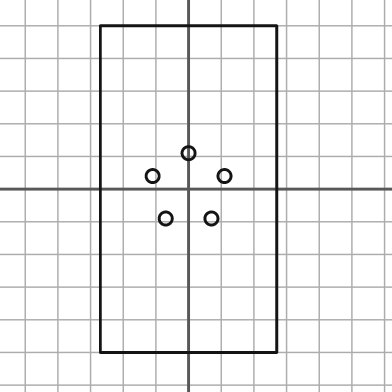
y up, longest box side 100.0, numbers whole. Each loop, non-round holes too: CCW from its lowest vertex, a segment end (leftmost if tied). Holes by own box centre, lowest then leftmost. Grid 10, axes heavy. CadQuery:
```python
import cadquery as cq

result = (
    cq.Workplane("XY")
    .moveTo(-27.0, -50.0)
    .lineTo(27.0, -50.0)
    .lineTo(27.0, 50.0)
    .lineTo(-27.0, 50.0)
    .close()
    .moveTo(-7.0, -9.0)
    .circle(2.0)
    .moveTo(7.0, -9.0)
    .circle(2.0)
    .moveTo(-11.0, 4.0)
    .circle(2.0)
    .moveTo(11.0, 4.0)
    .circle(2.0)
    .moveTo(0.0, 11.0)
    .circle(2.0)
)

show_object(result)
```